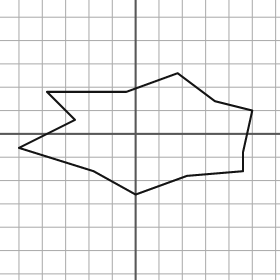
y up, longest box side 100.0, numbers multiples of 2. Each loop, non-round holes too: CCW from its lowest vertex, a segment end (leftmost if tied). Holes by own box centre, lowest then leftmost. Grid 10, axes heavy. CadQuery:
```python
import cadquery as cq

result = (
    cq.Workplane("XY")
    .moveTo(0.0, -26.0)
    .lineTo(22.0, -18.0)
    .lineTo(46.0, -16.0)
    .lineTo(46.0, -8.0)
    .lineTo(50.0, 10.0)
    .lineTo(34.0, 14.0)
    .lineTo(18.0, 26.0)
    .lineTo(-4.0, 18.0)
    .lineTo(-38.0, 18.0)
    .lineTo(-26.0, 6.0)
    .lineTo(-50.0, -6.0)
    .lineTo(-18.0, -16.0)
    .close()
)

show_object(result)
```